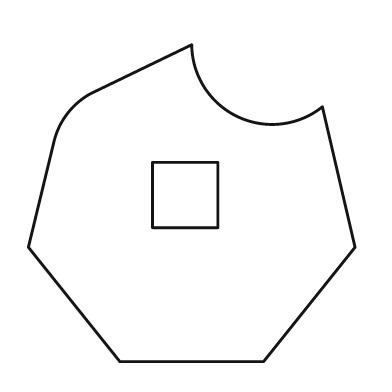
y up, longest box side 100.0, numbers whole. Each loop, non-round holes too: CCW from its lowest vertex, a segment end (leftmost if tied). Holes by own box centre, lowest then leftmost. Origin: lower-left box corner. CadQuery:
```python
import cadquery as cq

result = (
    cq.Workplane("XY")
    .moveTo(28.0, 0.0)
    .lineTo(72.0, 0.0)
    .lineTo(100.0, 35.0)
    .lineTo(90.0, 78.0)
    .threePointArc((64.0, 75.0), (50.0, 97.0))
    .lineTo(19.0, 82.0)
    .threePointArc((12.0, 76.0), (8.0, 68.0))
    .lineTo(0.0, 35.0)
    .close()
    .moveTo(38.0, 41.0)
    .lineTo(58.0, 41.0)
    .lineTo(58.0, 61.0)
    .lineTo(38.0, 61.0)
    .close()
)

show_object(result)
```